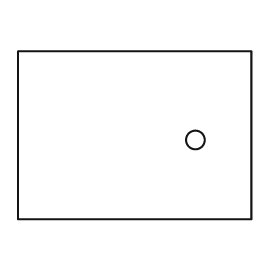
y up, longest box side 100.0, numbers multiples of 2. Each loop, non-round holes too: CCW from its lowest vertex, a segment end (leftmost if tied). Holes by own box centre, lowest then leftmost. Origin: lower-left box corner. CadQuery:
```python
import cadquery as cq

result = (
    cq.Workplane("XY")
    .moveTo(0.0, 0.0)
    .lineTo(100.0, 0.0)
    .lineTo(100.0, 72.0)
    .lineTo(0.0, 72.0)
    .close()
    .moveTo(76.0, 34.0)
    .circle(4.0)
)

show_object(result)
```